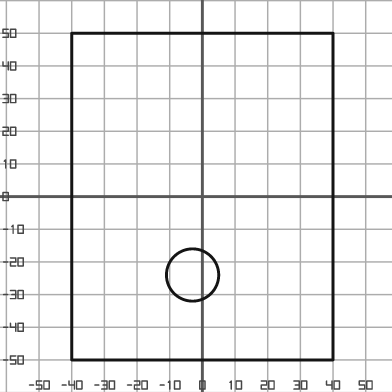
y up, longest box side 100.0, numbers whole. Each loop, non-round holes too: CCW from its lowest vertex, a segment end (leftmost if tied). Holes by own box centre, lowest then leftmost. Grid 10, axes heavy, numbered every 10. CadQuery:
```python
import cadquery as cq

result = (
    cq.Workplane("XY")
    .moveTo(-40.0, -50.0)
    .lineTo(40.0, -50.0)
    .lineTo(40.0, 50.0)
    .lineTo(-40.0, 50.0)
    .close()
    .moveTo(-3.0, -24.0)
    .circle(8.0)
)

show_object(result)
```